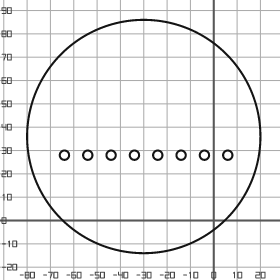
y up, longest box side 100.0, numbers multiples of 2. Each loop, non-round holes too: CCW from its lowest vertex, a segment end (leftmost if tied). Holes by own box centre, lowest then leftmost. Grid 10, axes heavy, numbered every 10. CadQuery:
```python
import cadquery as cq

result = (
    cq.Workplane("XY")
    .moveTo(-30.0, 36.0)
    .circle(50.0)
    .moveTo(-64.0, 28.0)
    .circle(2.0)
    .moveTo(-54.0, 28.0)
    .circle(2.0)
    .moveTo(-44.0, 28.0)
    .circle(2.0)
    .moveTo(-34.0, 28.0)
    .circle(2.0)
    .moveTo(-24.0, 28.0)
    .circle(2.0)
    .moveTo(-14.0, 28.0)
    .circle(2.0)
    .moveTo(-4.0, 28.0)
    .circle(2.0)
    .moveTo(6.0, 28.0)
    .circle(2.0)
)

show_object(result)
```